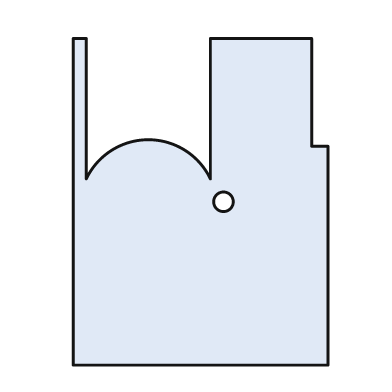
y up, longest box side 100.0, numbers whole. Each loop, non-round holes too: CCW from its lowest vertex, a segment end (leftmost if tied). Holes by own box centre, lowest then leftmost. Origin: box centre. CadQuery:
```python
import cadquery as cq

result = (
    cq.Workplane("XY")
    .moveTo(-39.0, -50.0)
    .lineTo(39.0, -50.0)
    .lineTo(39.0, 17.0)
    .lineTo(34.0, 17.0)
    .lineTo(34.0, 50.0)
    .lineTo(3.0, 50.0)
    .lineTo(3.0, 7.0)
    .threePointArc((-16.0, 19.0), (-35.0, 7.0))
    .lineTo(-35.0, 50.0)
    .lineTo(-39.0, 50.0)
    .close()
    .moveTo(7.0, 0.0)
    .circle(3.0)
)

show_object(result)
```